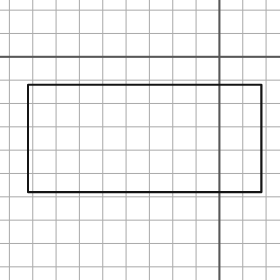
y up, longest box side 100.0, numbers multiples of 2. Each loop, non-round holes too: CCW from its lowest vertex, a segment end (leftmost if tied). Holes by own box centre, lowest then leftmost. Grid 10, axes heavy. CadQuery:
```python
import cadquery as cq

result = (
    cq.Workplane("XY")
    .moveTo(-82.0, -58.0)
    .lineTo(18.0, -58.0)
    .lineTo(18.0, -12.0)
    .lineTo(-82.0, -12.0)
    .close()
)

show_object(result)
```